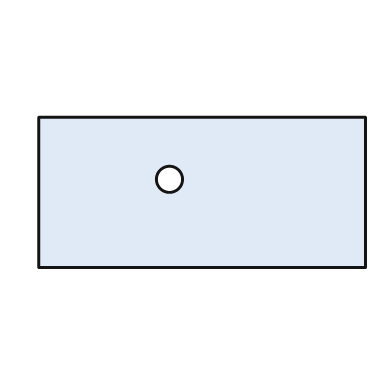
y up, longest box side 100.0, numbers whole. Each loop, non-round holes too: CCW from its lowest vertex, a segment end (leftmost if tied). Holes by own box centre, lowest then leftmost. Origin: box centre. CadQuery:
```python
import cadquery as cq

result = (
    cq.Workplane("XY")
    .moveTo(-50.0, -23.0)
    .lineTo(50.0, -23.0)
    .lineTo(50.0, 23.0)
    .lineTo(-50.0, 23.0)
    .close()
    .moveTo(-10.0, 4.0)
    .circle(4.0)
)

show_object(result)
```